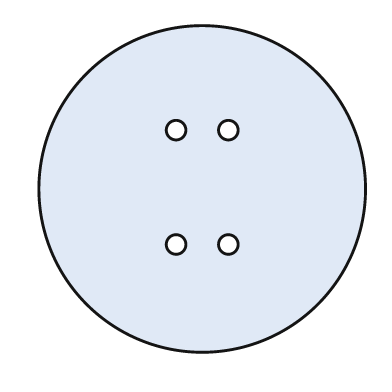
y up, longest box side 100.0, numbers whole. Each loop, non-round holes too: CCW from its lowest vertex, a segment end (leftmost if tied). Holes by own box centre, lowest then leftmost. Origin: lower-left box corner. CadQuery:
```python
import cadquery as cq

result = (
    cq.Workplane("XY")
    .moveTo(50.0, 50.0)
    .circle(50.0)
    .moveTo(42.0, 33.0)
    .circle(3.0)
    .moveTo(58.0, 33.0)
    .circle(3.0)
    .moveTo(42.0, 68.0)
    .circle(3.0)
    .moveTo(58.0, 68.0)
    .circle(3.0)
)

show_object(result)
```